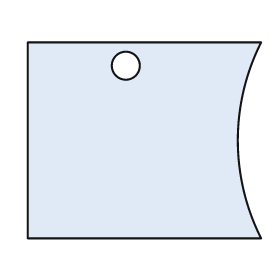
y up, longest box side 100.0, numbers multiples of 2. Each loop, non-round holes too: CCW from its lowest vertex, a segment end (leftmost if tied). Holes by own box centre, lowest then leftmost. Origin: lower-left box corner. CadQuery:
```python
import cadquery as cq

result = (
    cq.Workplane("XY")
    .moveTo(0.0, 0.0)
    .lineTo(100.0, 0.0)
    .threePointArc((90.0, 42.0), (100.0, 84.0))
    .lineTo(0.0, 84.0)
    .close()
    .moveTo(42.0, 74.0)
    .circle(6.0)
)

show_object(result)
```